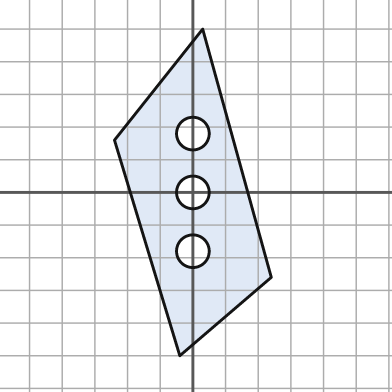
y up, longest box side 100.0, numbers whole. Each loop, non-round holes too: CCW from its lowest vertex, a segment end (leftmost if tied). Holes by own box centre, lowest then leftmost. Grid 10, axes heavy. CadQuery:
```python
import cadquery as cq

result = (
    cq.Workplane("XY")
    .moveTo(-4.0, -50.0)
    .lineTo(24.0, -26.0)
    .lineTo(3.0, 50.0)
    .lineTo(-24.0, 16.0)
    .close()
    .moveTo(0.0, -18.0)
    .circle(5.0)
    .moveTo(0.0, 0.0)
    .circle(5.0)
    .moveTo(0.0, 18.0)
    .circle(5.0)
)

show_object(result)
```